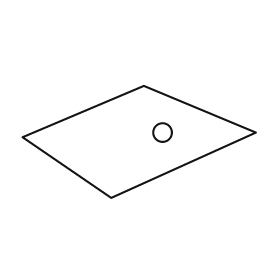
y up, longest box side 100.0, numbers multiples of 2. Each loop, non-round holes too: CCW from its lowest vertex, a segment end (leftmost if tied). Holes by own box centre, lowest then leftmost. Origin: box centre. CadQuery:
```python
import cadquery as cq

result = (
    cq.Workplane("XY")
    .moveTo(-12.0, -24.0)
    .lineTo(50.0, 4.0)
    .lineTo(2.0, 24.0)
    .lineTo(-50.0, 2.0)
    .close()
    .moveTo(10.0, 4.0)
    .circle(4.0)
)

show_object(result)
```